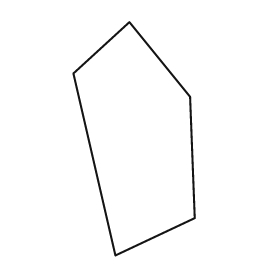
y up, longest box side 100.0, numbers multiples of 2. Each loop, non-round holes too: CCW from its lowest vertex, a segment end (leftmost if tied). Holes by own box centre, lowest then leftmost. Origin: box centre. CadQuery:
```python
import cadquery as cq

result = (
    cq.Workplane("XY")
    .moveTo(-8.0, -50.0)
    .lineTo(26.0, -34.0)
    .lineTo(24.0, 18.0)
    .lineTo(-2.0, 50.0)
    .lineTo(-26.0, 28.0)
    .close()
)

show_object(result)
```